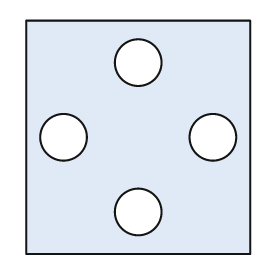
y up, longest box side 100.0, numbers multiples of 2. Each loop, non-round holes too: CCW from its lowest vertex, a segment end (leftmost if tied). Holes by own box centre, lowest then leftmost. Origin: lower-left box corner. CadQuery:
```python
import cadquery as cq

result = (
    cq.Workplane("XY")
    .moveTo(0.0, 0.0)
    .lineTo(96.0, 0.0)
    .lineTo(96.0, 100.0)
    .lineTo(0.0, 100.0)
    .close()
    .moveTo(48.0, 18.0)
    .circle(10.0)
    .moveTo(16.0, 50.0)
    .circle(10.0)
    .moveTo(80.0, 50.0)
    .circle(10.0)
    .moveTo(48.0, 82.0)
    .circle(10.0)
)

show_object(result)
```